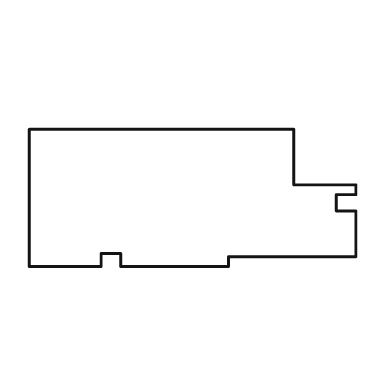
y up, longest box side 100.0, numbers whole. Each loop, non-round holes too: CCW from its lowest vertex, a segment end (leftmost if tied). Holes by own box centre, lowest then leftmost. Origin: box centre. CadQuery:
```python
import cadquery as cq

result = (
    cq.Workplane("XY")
    .moveTo(-50.0, -21.0)
    .lineTo(-28.0, -21.0)
    .lineTo(-28.0, -17.0)
    .lineTo(-22.0, -17.0)
    .lineTo(-22.0, -21.0)
    .lineTo(11.0, -21.0)
    .lineTo(11.0, -18.0)
    .lineTo(50.0, -18.0)
    .lineTo(50.0, -4.0)
    .lineTo(44.0, -4.0)
    .lineTo(44.0, 1.0)
    .lineTo(50.0, 1.0)
    .lineTo(50.0, 4.0)
    .lineTo(31.0, 4.0)
    .lineTo(31.0, 21.0)
    .lineTo(-50.0, 21.0)
    .close()
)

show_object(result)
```